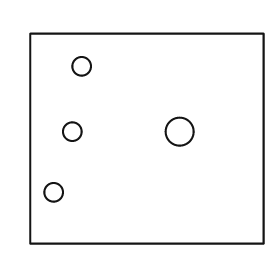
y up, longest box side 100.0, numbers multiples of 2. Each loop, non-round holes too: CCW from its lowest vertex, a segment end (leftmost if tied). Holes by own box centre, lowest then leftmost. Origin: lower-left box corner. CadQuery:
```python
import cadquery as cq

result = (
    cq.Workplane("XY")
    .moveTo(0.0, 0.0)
    .lineTo(100.0, 0.0)
    .lineTo(100.0, 90.0)
    .lineTo(0.0, 90.0)
    .close()
    .moveTo(10.0, 22.0)
    .circle(4.0)
    .moveTo(18.0, 48.0)
    .circle(4.0)
    .moveTo(64.0, 48.0)
    .circle(6.0)
    .moveTo(22.0, 76.0)
    .circle(4.0)
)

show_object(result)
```